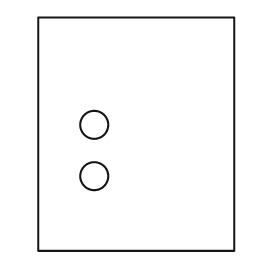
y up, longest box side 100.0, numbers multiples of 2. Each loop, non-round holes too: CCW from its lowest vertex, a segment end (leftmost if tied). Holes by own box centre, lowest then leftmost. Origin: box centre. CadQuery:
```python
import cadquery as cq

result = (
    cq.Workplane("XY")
    .moveTo(-42.0, -50.0)
    .lineTo(42.0, -50.0)
    .lineTo(42.0, 50.0)
    .lineTo(-42.0, 50.0)
    .close()
    .moveTo(-18.0, -18.0)
    .circle(6.0)
    .moveTo(-18.0, 4.0)
    .circle(6.0)
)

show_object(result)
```